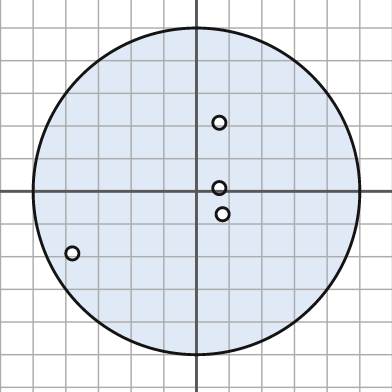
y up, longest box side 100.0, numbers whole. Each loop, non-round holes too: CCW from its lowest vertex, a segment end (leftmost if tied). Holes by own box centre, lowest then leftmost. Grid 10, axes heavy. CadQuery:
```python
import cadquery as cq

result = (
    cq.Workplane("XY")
    .moveTo(0.0, 0.0)
    .circle(50.0)
    .moveTo(-38.0, -19.0)
    .circle(2.0)
    .moveTo(8.0, -7.0)
    .circle(2.0)
    .moveTo(7.0, 1.0)
    .circle(2.0)
    .moveTo(7.0, 21.0)
    .circle(2.0)
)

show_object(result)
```